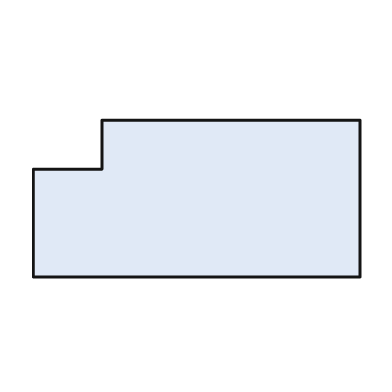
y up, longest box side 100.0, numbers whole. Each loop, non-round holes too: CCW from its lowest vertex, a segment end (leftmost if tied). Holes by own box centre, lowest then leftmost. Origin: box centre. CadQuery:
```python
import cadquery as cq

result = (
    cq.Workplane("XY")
    .moveTo(-50.0, -24.0)
    .lineTo(50.0, -24.0)
    .lineTo(50.0, 24.0)
    .lineTo(-29.0, 24.0)
    .lineTo(-29.0, 9.0)
    .lineTo(-50.0, 9.0)
    .close()
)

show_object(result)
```